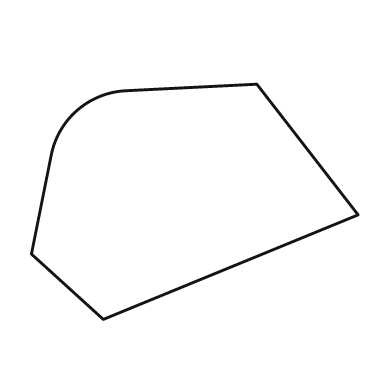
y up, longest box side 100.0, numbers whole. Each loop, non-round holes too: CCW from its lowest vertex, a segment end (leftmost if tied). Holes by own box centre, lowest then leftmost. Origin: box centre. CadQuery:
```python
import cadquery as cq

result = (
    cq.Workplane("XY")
    .moveTo(-28.0, -36.0)
    .lineTo(50.0, -4.0)
    .lineTo(19.0, 36.0)
    .lineTo(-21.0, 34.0)
    .threePointArc((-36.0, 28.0), (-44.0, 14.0))
    .lineTo(-50.0, -16.0)
    .close()
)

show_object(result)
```